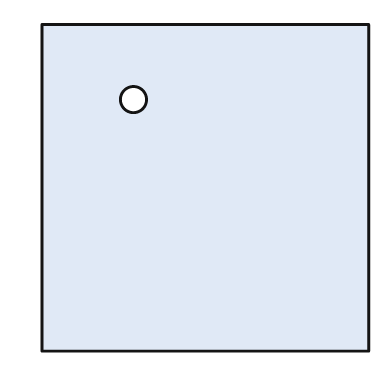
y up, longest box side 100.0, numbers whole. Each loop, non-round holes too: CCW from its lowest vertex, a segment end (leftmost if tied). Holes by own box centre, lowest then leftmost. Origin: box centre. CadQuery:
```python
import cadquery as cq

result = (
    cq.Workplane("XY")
    .moveTo(-50.0, -50.0)
    .lineTo(50.0, -50.0)
    .lineTo(50.0, 50.0)
    .lineTo(-50.0, 50.0)
    .close()
    .moveTo(-22.0, 27.0)
    .circle(4.0)
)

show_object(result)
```